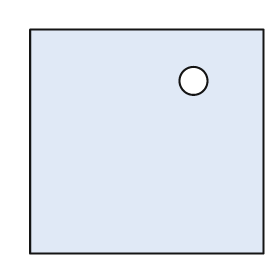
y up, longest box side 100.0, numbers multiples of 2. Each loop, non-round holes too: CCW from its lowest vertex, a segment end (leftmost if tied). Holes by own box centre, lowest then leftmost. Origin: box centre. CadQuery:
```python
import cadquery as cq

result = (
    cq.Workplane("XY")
    .moveTo(-50.0, -48.0)
    .lineTo(50.0, -48.0)
    .lineTo(50.0, 48.0)
    .lineTo(-50.0, 48.0)
    .close()
    .moveTo(20.0, 26.0)
    .circle(6.0)
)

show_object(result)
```